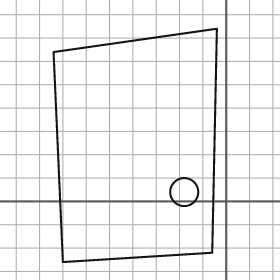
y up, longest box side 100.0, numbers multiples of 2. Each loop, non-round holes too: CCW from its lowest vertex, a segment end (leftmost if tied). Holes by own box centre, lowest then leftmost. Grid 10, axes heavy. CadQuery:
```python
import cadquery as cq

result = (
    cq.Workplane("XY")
    .moveTo(-70.0, -26.0)
    .lineTo(-6.0, -22.0)
    .lineTo(-4.0, 74.0)
    .lineTo(-74.0, 64.0)
    .close()
    .moveTo(-18.0, 4.0)
    .circle(6.0)
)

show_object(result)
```